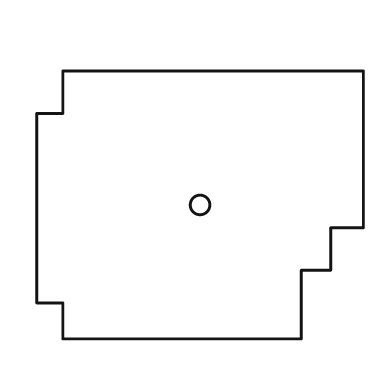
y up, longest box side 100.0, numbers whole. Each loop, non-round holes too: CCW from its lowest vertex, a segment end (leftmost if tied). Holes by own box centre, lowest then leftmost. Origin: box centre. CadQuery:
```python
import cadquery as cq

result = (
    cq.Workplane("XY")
    .moveTo(-42.0, -41.0)
    .lineTo(31.0, -41.0)
    .lineTo(31.0, -20.0)
    .lineTo(40.0, -20.0)
    .lineTo(40.0, -7.0)
    .lineTo(50.0, -7.0)
    .lineTo(50.0, 41.0)
    .lineTo(-42.0, 41.0)
    .lineTo(-42.0, 28.0)
    .lineTo(-50.0, 28.0)
    .lineTo(-50.0, -30.0)
    .lineTo(-42.0, -30.0)
    .close()
    .moveTo(0.0, 0.0)
    .circle(3.0)
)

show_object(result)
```